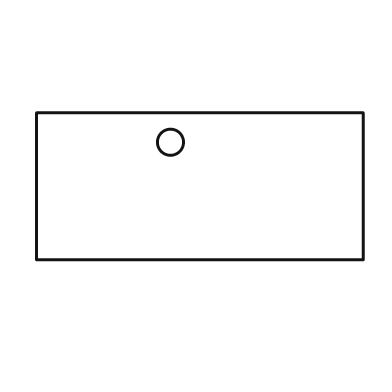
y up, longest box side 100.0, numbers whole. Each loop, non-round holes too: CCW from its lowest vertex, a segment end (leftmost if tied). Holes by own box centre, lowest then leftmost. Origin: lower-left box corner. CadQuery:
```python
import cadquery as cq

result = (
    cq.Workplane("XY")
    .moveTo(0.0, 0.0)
    .lineTo(100.0, 0.0)
    .lineTo(100.0, 45.0)
    .lineTo(0.0, 45.0)
    .close()
    .moveTo(41.0, 36.0)
    .circle(4.0)
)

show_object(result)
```